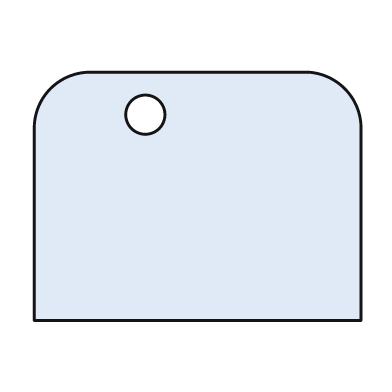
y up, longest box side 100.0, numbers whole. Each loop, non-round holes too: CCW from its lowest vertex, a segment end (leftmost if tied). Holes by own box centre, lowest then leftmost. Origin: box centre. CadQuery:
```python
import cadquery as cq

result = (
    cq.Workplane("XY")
    .moveTo(-50.0, -38.0)
    .lineTo(50.0, -38.0)
    .lineTo(50.0, 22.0)
    .threePointArc((45.0, 33.0), (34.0, 38.0))
    .lineTo(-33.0, 38.0)
    .threePointArc((-45.0, 33.0), (-50.0, 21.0))
    .close()
    .moveTo(-16.0, 25.0)
    .circle(6.0)
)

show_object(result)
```